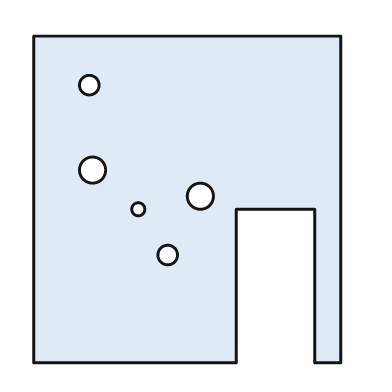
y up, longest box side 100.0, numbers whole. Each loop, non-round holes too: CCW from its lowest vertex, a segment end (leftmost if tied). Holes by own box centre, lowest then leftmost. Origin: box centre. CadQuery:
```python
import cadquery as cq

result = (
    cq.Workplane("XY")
    .moveTo(-47.0, -50.0)
    .lineTo(15.0, -50.0)
    .lineTo(15.0, -3.0)
    .lineTo(39.0, -3.0)
    .lineTo(39.0, -50.0)
    .lineTo(47.0, -50.0)
    .lineTo(47.0, 50.0)
    .lineTo(-47.0, 50.0)
    .close()
    .moveTo(-6.0, -17.0)
    .circle(3.0)
    .moveTo(-15.0, -3.0)
    .circle(2.0)
    .moveTo(4.0, 1.0)
    .circle(4.0)
    .moveTo(-29.0, 9.0)
    .circle(4.0)
    .moveTo(-30.0, 35.0)
    .circle(3.0)
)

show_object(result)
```